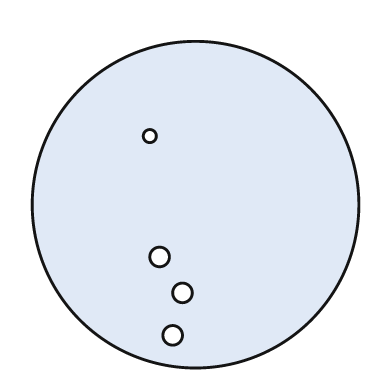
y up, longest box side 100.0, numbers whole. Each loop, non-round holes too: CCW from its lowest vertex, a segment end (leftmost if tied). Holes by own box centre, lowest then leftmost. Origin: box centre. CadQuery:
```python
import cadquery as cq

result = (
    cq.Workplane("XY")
    .moveTo(0.0, 0.0)
    .circle(50.0)
    .moveTo(-7.0, -40.0)
    .circle(3.0)
    .moveTo(-4.0, -27.0)
    .circle(3.0)
    .moveTo(-11.0, -16.0)
    .circle(3.0)
    .moveTo(-14.0, 21.0)
    .circle(2.0)
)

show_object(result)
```